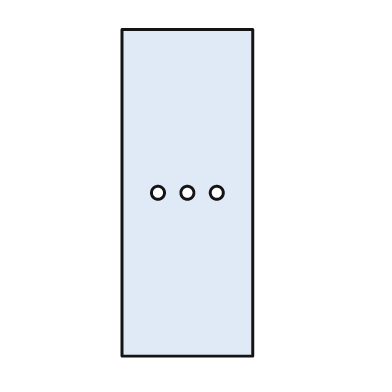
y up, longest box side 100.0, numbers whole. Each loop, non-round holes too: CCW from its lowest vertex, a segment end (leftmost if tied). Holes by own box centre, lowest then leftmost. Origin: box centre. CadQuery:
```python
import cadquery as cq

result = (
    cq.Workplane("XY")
    .moveTo(-20.0, -50.0)
    .lineTo(20.0, -50.0)
    .lineTo(20.0, 50.0)
    .lineTo(-20.0, 50.0)
    .close()
    .moveTo(-9.0, 0.0)
    .circle(2.0)
    .moveTo(0.0, 0.0)
    .circle(2.0)
    .moveTo(9.0, 0.0)
    .circle(2.0)
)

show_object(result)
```